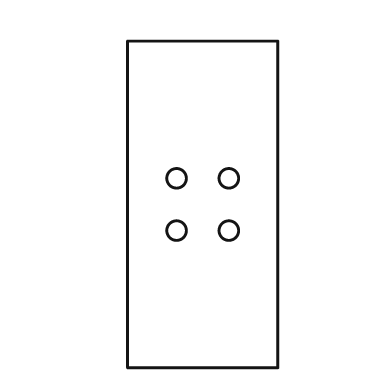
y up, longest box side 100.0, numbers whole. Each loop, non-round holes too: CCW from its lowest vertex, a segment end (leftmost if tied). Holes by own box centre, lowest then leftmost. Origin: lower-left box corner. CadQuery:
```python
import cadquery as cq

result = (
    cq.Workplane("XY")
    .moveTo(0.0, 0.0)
    .lineTo(46.0, 0.0)
    .lineTo(46.0, 100.0)
    .lineTo(0.0, 100.0)
    .close()
    .moveTo(15.0, 42.0)
    .circle(3.0)
    .moveTo(31.0, 42.0)
    .circle(3.0)
    .moveTo(15.0, 58.0)
    .circle(3.0)
    .moveTo(31.0, 58.0)
    .circle(3.0)
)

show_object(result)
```